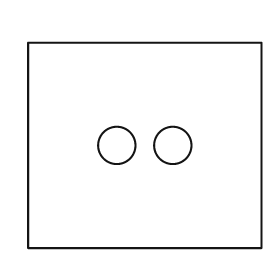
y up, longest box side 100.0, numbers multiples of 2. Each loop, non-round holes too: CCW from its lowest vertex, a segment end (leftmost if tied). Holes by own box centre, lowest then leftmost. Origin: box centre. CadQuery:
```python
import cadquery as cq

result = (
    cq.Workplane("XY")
    .moveTo(-50.0, -44.0)
    .lineTo(50.0, -44.0)
    .lineTo(50.0, 44.0)
    .lineTo(-50.0, 44.0)
    .close()
    .moveTo(-12.0, 0.0)
    .circle(8.0)
    .moveTo(12.0, 0.0)
    .circle(8.0)
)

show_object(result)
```